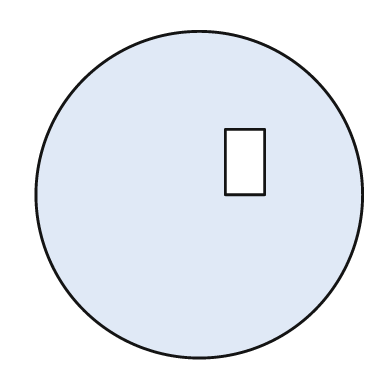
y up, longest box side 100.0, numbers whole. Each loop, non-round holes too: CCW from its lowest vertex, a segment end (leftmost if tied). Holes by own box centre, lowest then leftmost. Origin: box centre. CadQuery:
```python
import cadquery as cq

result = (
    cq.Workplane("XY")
    .moveTo(0.0, 0.0)
    .circle(50.0)
    .moveTo(8.0, 0.0)
    .lineTo(20.0, 0.0)
    .lineTo(20.0, 20.0)
    .lineTo(8.0, 20.0)
    .close()
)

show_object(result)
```